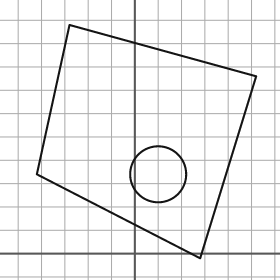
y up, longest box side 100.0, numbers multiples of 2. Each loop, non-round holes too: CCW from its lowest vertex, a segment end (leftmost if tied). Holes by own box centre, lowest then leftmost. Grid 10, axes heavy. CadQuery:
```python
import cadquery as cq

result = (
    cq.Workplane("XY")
    .moveTo(28.0, -2.0)
    .lineTo(52.0, 76.0)
    .lineTo(-28.0, 98.0)
    .lineTo(-42.0, 34.0)
    .close()
    .moveTo(10.0, 34.0)
    .circle(12.0)
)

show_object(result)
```